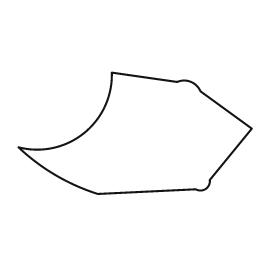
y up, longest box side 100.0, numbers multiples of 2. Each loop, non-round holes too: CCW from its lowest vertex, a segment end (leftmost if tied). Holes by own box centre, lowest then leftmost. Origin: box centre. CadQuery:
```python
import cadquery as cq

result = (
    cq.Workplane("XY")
    .moveTo(-16.0, -26.0)
    .lineTo(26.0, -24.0)
    .threePointArc((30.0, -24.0), (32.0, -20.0))
    .lineTo(50.0, 2.0)
    .lineTo(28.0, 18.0)
    .threePointArc((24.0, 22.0), (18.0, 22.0))
    .lineTo(-10.0, 26.0)
    .threePointArc((-22.0, 0.0), (-50.0, -6.0))
    .threePointArc((-34.0, -18.0), (-16.0, -26.0))
    .close()
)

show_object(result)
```